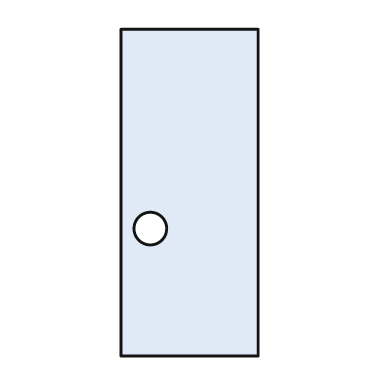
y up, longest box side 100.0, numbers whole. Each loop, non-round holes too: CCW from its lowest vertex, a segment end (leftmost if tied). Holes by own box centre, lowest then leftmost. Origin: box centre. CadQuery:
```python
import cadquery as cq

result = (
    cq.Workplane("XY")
    .moveTo(-21.0, -50.0)
    .lineTo(21.0, -50.0)
    .lineTo(21.0, 50.0)
    .lineTo(-21.0, 50.0)
    .close()
    .moveTo(-12.0, -11.0)
    .circle(5.0)
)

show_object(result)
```